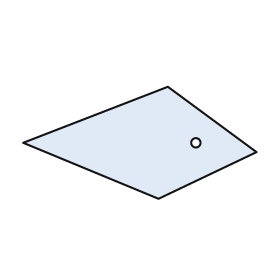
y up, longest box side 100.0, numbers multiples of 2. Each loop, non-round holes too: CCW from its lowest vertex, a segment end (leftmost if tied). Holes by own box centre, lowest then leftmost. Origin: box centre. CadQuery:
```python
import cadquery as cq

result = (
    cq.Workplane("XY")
    .moveTo(8.0, -24.0)
    .lineTo(50.0, -4.0)
    .lineTo(12.0, 24.0)
    .lineTo(-50.0, 0.0)
    .close()
    .moveTo(24.0, 0.0)
    .circle(2.0)
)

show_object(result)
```